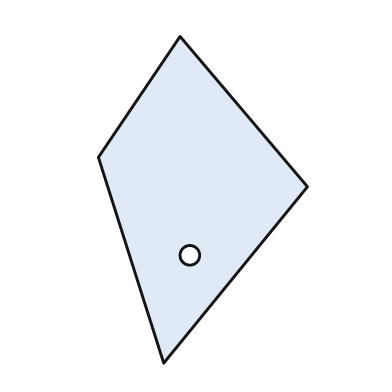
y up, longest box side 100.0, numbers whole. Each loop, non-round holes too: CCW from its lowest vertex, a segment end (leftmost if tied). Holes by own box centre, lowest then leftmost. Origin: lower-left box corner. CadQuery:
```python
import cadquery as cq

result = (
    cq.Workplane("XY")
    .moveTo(20.0, 0.0)
    .lineTo(64.0, 54.0)
    .lineTo(25.0, 100.0)
    .lineTo(0.0, 63.0)
    .close()
    .moveTo(28.0, 33.0)
    .circle(3.0)
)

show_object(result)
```